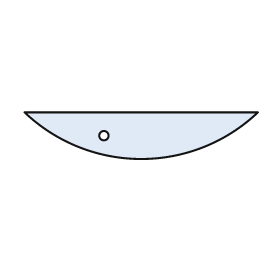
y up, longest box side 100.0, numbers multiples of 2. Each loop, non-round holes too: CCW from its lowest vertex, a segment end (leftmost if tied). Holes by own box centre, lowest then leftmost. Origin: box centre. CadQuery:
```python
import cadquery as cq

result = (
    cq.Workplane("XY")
    .moveTo(-50.0, 10.0)
    .threePointArc((0.0, -10.0), (50.0, 10.0))
    .close()
    .moveTo(-16.0, 0.0)
    .circle(2.0)
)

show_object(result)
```